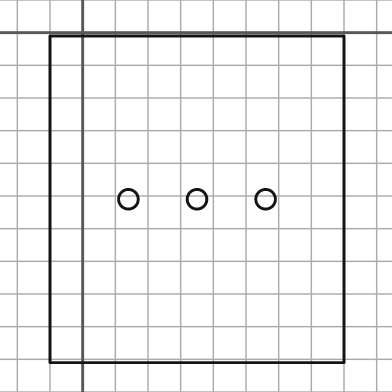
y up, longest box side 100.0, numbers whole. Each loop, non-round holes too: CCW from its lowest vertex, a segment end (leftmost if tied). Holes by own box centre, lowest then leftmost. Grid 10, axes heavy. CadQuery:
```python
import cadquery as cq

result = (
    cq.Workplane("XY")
    .moveTo(-10.0, -101.0)
    .lineTo(80.0, -101.0)
    .lineTo(80.0, -1.0)
    .lineTo(-10.0, -1.0)
    .close()
    .moveTo(14.0, -51.0)
    .circle(3.0)
    .moveTo(35.0, -51.0)
    .circle(3.0)
    .moveTo(56.0, -51.0)
    .circle(3.0)
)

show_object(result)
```